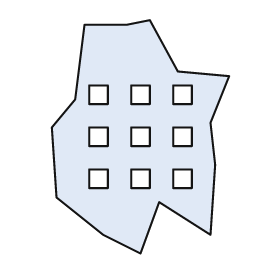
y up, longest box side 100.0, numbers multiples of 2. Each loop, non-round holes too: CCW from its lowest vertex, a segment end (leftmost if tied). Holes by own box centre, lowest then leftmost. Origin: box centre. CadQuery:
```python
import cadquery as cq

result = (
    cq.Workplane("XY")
    .moveTo(0.0, -50.0)
    .lineTo(8.0, -28.0)
    .lineTo(30.0, -42.0)
    .lineTo(32.0, -12.0)
    .lineTo(30.0, 6.0)
    .lineTo(38.0, 26.0)
    .lineTo(16.0, 28.0)
    .lineTo(4.0, 50.0)
    .lineTo(-6.0, 48.0)
    .lineTo(-24.0, 48.0)
    .lineTo(-28.0, 16.0)
    .lineTo(-38.0, 4.0)
    .lineTo(-36.0, -26.0)
    .lineTo(-16.0, -42.0)
    .close()
    .moveTo(-22.0, -22.0)
    .lineTo(-14.0, -22.0)
    .lineTo(-14.0, -14.0)
    .lineTo(-22.0, -14.0)
    .close()
    .moveTo(-4.0, -22.0)
    .lineTo(4.0, -22.0)
    .lineTo(4.0, -14.0)
    .lineTo(-4.0, -14.0)
    .close()
    .moveTo(14.0, -22.0)
    .lineTo(22.0, -22.0)
    .lineTo(22.0, -14.0)
    .lineTo(14.0, -14.0)
    .close()
    .moveTo(-22.0, -4.0)
    .lineTo(-14.0, -4.0)
    .lineTo(-14.0, 4.0)
    .lineTo(-22.0, 4.0)
    .close()
    .moveTo(-4.0, -4.0)
    .lineTo(4.0, -4.0)
    .lineTo(4.0, 4.0)
    .lineTo(-4.0, 4.0)
    .close()
    .moveTo(14.0, -4.0)
    .lineTo(22.0, -4.0)
    .lineTo(22.0, 4.0)
    .lineTo(14.0, 4.0)
    .close()
    .moveTo(-22.0, 14.0)
    .lineTo(-14.0, 14.0)
    .lineTo(-14.0, 22.0)
    .lineTo(-22.0, 22.0)
    .close()
    .moveTo(-4.0, 14.0)
    .lineTo(4.0, 14.0)
    .lineTo(4.0, 22.0)
    .lineTo(-4.0, 22.0)
    .close()
    .moveTo(14.0, 14.0)
    .lineTo(22.0, 14.0)
    .lineTo(22.0, 22.0)
    .lineTo(14.0, 22.0)
    .close()
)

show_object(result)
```